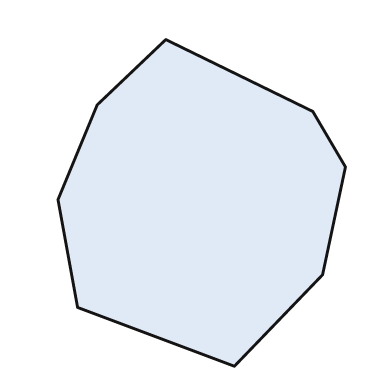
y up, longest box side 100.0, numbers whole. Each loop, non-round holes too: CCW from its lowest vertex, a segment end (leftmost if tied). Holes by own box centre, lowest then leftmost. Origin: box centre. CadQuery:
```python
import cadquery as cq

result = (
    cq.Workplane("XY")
    .moveTo(10.0, -50.0)
    .lineTo(37.0, -22.0)
    .lineTo(44.0, 11.0)
    .lineTo(34.0, 28.0)
    .lineTo(-11.0, 50.0)
    .lineTo(-32.0, 30.0)
    .lineTo(-44.0, 1.0)
    .lineTo(-38.0, -32.0)
    .close()
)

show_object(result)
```